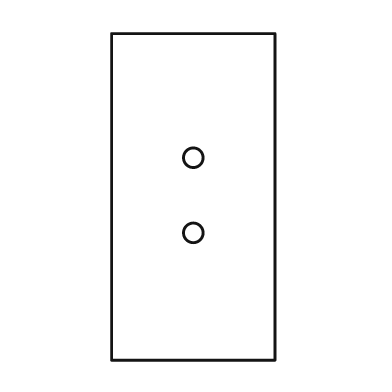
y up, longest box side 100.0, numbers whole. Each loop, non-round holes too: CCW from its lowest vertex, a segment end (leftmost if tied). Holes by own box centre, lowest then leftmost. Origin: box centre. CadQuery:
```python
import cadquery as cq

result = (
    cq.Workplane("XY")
    .moveTo(-25.0, -50.0)
    .lineTo(25.0, -50.0)
    .lineTo(25.0, 50.0)
    .lineTo(-25.0, 50.0)
    .close()
    .moveTo(0.0, -11.0)
    .circle(3.0)
    .moveTo(0.0, 12.0)
    .circle(3.0)
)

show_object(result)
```